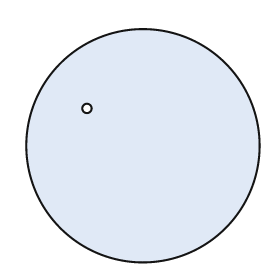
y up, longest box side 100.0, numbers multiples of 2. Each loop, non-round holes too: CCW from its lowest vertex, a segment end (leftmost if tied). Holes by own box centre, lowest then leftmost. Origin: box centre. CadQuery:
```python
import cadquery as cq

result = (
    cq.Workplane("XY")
    .moveTo(0.0, 0.0)
    .circle(50.0)
    .moveTo(-24.0, 16.0)
    .circle(2.0)
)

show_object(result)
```